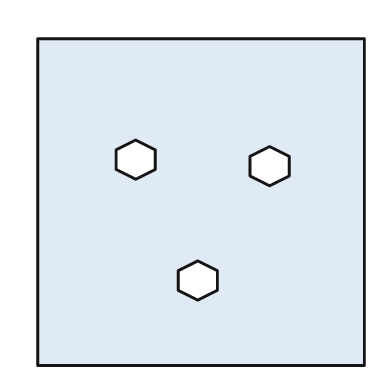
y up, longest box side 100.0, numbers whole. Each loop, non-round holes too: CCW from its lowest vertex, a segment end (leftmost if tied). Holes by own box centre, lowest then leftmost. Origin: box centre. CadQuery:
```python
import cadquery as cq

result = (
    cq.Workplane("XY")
    .moveTo(-50.0, -50.0)
    .lineTo(50.0, -50.0)
    .lineTo(50.0, 50.0)
    .lineTo(-50.0, 50.0)
    .close()
    .moveTo(-1.0, -30.0)
    .lineTo(5.0, -27.0)
    .lineTo(5.0, -21.0)
    .lineTo(-1.0, -18.0)
    .lineTo(-7.0, -21.0)
    .lineTo(-7.0, -27.0)
    .close()
    .moveTo(21.0, 5.0)
    .lineTo(27.0, 8.0)
    .lineTo(27.0, 14.0)
    .lineTo(21.0, 17.0)
    .lineTo(15.0, 14.0)
    .lineTo(15.0, 8.0)
    .close()
    .moveTo(-20.0, 7.0)
    .lineTo(-14.0, 10.0)
    .lineTo(-14.0, 16.0)
    .lineTo(-20.0, 19.0)
    .lineTo(-26.0, 16.0)
    .lineTo(-26.0, 10.0)
    .close()
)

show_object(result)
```